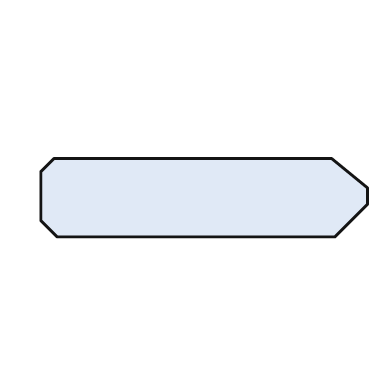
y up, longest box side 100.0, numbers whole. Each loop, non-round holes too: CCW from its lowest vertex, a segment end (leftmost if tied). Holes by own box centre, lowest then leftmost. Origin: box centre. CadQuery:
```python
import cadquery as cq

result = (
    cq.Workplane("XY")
    .moveTo(-45.0, -12.0)
    .lineTo(40.0, -12.0)
    .lineTo(50.0, -2.0)
    .lineTo(50.0, 3.0)
    .lineTo(39.0, 12.0)
    .lineTo(-46.0, 12.0)
    .lineTo(-50.0, 8.0)
    .lineTo(-50.0, -7.0)
    .close()
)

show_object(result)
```